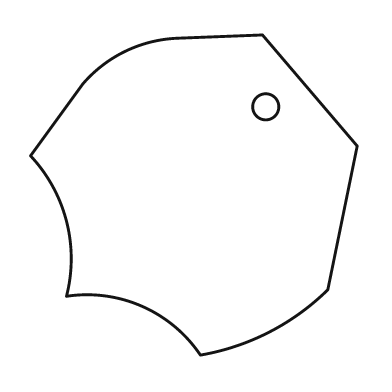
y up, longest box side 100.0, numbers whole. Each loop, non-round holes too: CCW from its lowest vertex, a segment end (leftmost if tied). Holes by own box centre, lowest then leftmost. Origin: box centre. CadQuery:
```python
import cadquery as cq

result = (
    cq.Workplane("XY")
    .moveTo(2.0, -49.0)
    .threePointArc((23.0, -42.0), (41.0, -29.0))
    .lineTo(50.0, 15.0)
    .lineTo(21.0, 49.0)
    .lineTo(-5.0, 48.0)
    .threePointArc((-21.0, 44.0), (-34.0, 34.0))
    .lineTo(-50.0, 12.0)
    .threePointArc((-39.0, -8.0), (-39.0, -31.0))
    .threePointArc((-16.0, -34.0), (2.0, -49.0))
    .close()
    .moveTo(22.0, 27.0)
    .circle(4.0)
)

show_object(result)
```